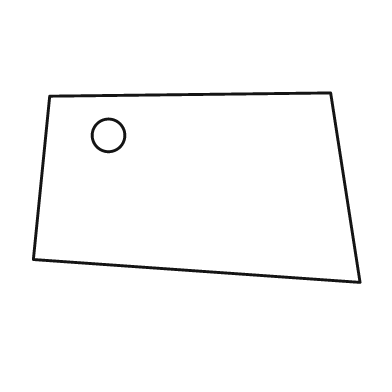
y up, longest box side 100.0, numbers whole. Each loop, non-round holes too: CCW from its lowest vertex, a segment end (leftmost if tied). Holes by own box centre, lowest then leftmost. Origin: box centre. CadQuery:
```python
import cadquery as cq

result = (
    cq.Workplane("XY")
    .moveTo(50.0, -29.0)
    .lineTo(41.0, 29.0)
    .lineTo(-45.0, 28.0)
    .lineTo(-50.0, -22.0)
    .close()
    .moveTo(-27.0, 16.0)
    .circle(5.0)
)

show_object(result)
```